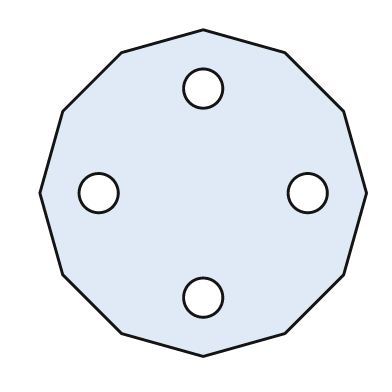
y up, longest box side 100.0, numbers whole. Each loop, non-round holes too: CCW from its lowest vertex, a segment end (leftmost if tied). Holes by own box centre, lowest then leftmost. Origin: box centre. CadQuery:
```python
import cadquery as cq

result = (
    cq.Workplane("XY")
    .moveTo(0.0, -50.0)
    .lineTo(25.0, -43.0)
    .lineTo(43.0, -25.0)
    .lineTo(50.0, 0.0)
    .lineTo(43.0, 25.0)
    .lineTo(25.0, 43.0)
    .lineTo(0.0, 50.0)
    .lineTo(-25.0, 43.0)
    .lineTo(-43.0, 25.0)
    .lineTo(-50.0, 0.0)
    .lineTo(-43.0, -25.0)
    .lineTo(-25.0, -43.0)
    .close()
    .moveTo(0.0, -32.0)
    .circle(6.0)
    .moveTo(-32.0, 0.0)
    .circle(6.0)
    .moveTo(32.0, 0.0)
    .circle(6.0)
    .moveTo(0.0, 32.0)
    .circle(6.0)
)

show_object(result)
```